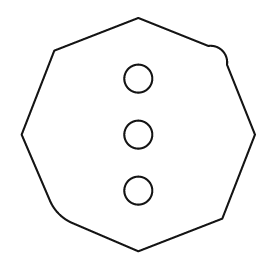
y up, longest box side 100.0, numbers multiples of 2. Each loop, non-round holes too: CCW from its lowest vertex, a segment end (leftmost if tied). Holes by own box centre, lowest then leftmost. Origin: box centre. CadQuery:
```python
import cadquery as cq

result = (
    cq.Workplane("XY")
    .moveTo(0.0, -50.0)
    .lineTo(36.0, -36.0)
    .lineTo(50.0, 0.0)
    .lineTo(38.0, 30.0)
    .threePointArc((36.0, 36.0), (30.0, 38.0))
    .lineTo(0.0, 50.0)
    .lineTo(-36.0, 36.0)
    .lineTo(-50.0, 0.0)
    .lineTo(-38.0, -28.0)
    .threePointArc((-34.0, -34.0), (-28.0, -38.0))
    .close()
    .moveTo(0.0, -24.0)
    .circle(6.0)
    .moveTo(0.0, 0.0)
    .circle(6.0)
    .moveTo(0.0, 24.0)
    .circle(6.0)
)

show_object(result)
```